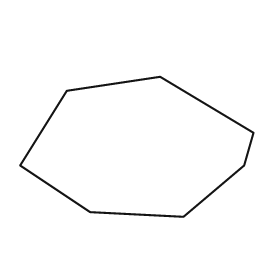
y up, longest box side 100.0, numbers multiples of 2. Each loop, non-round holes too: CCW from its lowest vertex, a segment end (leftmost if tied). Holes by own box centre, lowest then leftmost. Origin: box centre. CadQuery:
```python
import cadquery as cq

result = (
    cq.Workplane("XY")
    .moveTo(20.0, -30.0)
    .lineTo(46.0, -8.0)
    .lineTo(50.0, 6.0)
    .lineTo(10.0, 30.0)
    .lineTo(-30.0, 24.0)
    .lineTo(-50.0, -8.0)
    .lineTo(-20.0, -28.0)
    .close()
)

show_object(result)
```